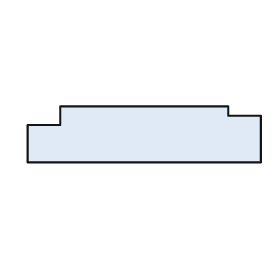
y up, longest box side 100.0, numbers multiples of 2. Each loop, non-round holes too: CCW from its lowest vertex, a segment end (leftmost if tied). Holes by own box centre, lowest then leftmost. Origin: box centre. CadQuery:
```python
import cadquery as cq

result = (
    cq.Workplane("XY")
    .moveTo(-50.0, -12.0)
    .lineTo(50.0, -12.0)
    .lineTo(50.0, 8.0)
    .lineTo(36.0, 8.0)
    .lineTo(36.0, 12.0)
    .lineTo(-36.0, 12.0)
    .lineTo(-36.0, 4.0)
    .lineTo(-50.0, 4.0)
    .close()
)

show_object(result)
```